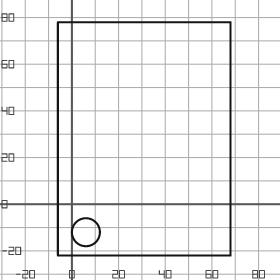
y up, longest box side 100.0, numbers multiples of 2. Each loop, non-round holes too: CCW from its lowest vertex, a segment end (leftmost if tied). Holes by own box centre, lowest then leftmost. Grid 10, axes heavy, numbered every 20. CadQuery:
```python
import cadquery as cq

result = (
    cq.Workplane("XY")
    .moveTo(-6.0, -22.0)
    .lineTo(68.0, -22.0)
    .lineTo(68.0, 78.0)
    .lineTo(-6.0, 78.0)
    .close()
    .moveTo(6.0, -12.0)
    .circle(6.0)
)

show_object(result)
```